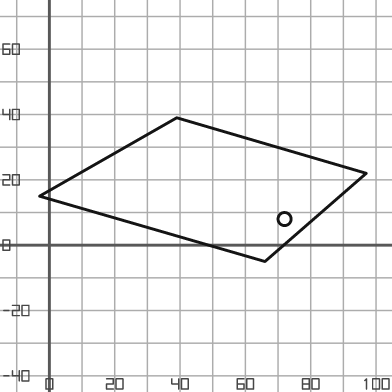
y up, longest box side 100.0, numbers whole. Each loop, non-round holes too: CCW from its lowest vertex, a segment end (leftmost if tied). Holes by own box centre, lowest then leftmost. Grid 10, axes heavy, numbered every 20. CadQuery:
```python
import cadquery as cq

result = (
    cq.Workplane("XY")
    .moveTo(66.0, -5.0)
    .lineTo(97.0, 22.0)
    .lineTo(39.0, 39.0)
    .lineTo(-3.0, 15.0)
    .close()
    .moveTo(72.0, 8.0)
    .circle(2.0)
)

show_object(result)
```